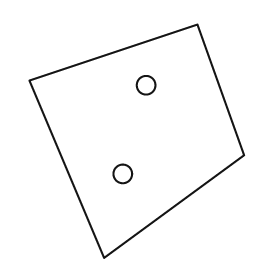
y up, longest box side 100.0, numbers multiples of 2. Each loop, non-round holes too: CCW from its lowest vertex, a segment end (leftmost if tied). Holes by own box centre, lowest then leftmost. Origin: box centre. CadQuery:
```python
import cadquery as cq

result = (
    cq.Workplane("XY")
    .moveTo(-14.0, -50.0)
    .lineTo(46.0, -6.0)
    .lineTo(26.0, 50.0)
    .lineTo(-46.0, 26.0)
    .close()
    .moveTo(-6.0, -14.0)
    .circle(4.0)
    .moveTo(4.0, 24.0)
    .circle(4.0)
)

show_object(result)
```